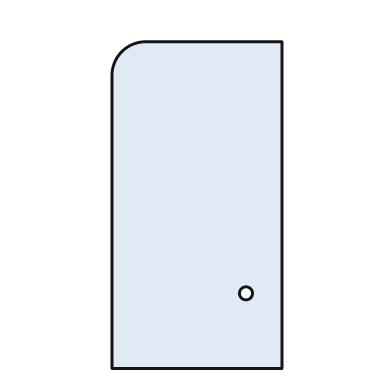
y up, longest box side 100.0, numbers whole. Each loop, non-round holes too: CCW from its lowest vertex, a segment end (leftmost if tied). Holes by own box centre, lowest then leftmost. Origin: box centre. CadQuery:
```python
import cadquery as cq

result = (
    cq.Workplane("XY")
    .moveTo(-26.0, -50.0)
    .lineTo(26.0, -50.0)
    .lineTo(26.0, 50.0)
    .lineTo(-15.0, 50.0)
    .threePointArc((-23.0, 47.0), (-26.0, 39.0))
    .close()
    .moveTo(15.0, -27.0)
    .circle(2.0)
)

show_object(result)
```